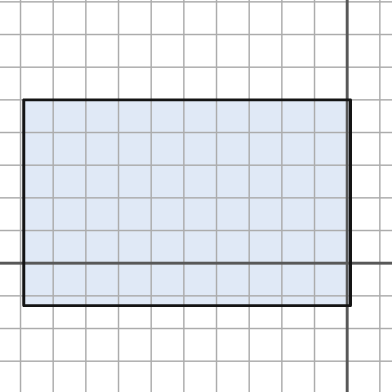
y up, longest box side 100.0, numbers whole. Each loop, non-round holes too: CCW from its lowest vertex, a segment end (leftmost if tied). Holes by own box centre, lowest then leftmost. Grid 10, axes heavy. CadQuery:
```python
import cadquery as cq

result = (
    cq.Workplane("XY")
    .moveTo(-99.0, -13.0)
    .lineTo(1.0, -13.0)
    .lineTo(1.0, 50.0)
    .lineTo(-99.0, 50.0)
    .close()
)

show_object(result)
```